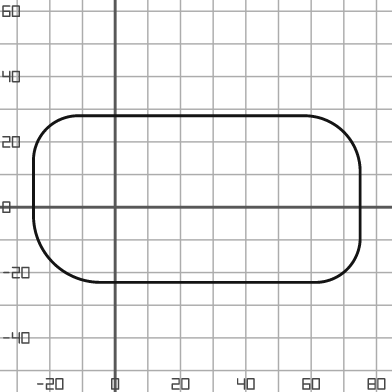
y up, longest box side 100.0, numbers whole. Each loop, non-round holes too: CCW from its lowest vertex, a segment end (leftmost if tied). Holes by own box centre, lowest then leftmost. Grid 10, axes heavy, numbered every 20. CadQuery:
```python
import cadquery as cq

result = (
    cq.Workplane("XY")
    .moveTo(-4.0, -23.0)
    .lineTo(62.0, -23.0)
    .threePointArc((71.0, -19.0), (75.0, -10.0))
    .lineTo(75.0, 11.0)
    .threePointArc((70.0, 23.0), (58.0, 28.0))
    .lineTo(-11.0, 28.0)
    .threePointArc((-21.0, 24.0), (-25.0, 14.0))
    .lineTo(-25.0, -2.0)
    .threePointArc((-19.0, -17.0), (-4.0, -23.0))
    .close()
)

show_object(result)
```